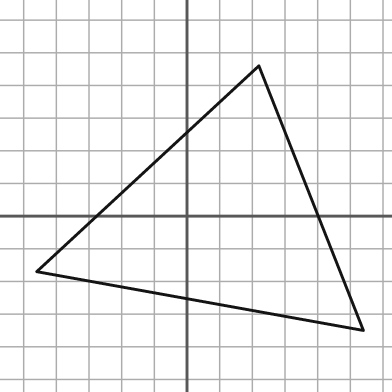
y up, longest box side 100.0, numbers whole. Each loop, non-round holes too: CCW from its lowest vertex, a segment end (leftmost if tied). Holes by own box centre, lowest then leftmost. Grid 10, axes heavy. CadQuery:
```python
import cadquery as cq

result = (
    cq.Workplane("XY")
    .moveTo(54.0, -35.0)
    .lineTo(22.0, 46.0)
    .lineTo(-46.0, -17.0)
    .close()
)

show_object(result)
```